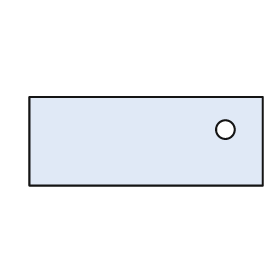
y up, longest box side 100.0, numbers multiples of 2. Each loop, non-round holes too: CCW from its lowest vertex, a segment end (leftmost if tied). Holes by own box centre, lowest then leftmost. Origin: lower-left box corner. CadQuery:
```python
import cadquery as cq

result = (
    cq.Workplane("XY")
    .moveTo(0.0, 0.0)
    .lineTo(100.0, 0.0)
    .lineTo(100.0, 38.0)
    .lineTo(0.0, 38.0)
    .close()
    .moveTo(84.0, 24.0)
    .circle(4.0)
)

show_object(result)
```